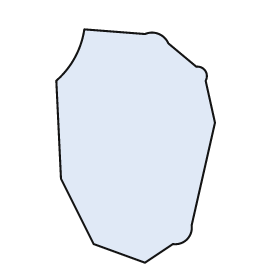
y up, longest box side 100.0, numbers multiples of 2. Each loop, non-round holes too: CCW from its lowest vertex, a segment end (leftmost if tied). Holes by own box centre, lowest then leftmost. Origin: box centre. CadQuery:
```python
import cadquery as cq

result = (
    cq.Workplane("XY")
    .moveTo(4.0, -50.0)
    .lineTo(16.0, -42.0)
    .threePointArc((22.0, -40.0), (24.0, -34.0))
    .lineTo(34.0, 10.0)
    .lineTo(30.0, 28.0)
    .threePointArc((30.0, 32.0), (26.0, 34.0))
    .lineTo(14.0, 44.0)
    .threePointArc((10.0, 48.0), (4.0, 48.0))
    .lineTo(-22.0, 50.0)
    .threePointArc((-26.0, 38.0), (-34.0, 28.0))
    .lineTo(-32.0, -14.0)
    .lineTo(-18.0, -42.0)
    .close()
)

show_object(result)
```